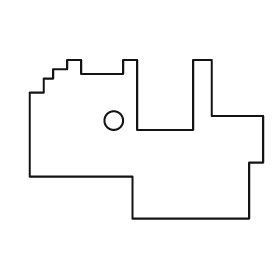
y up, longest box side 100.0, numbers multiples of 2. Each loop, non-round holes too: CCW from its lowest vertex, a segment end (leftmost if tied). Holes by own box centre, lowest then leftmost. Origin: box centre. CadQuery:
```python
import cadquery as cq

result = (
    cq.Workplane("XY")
    .moveTo(-6.0, -34.0)
    .lineTo(44.0, -34.0)
    .lineTo(44.0, -10.0)
    .lineTo(50.0, -10.0)
    .lineTo(50.0, 10.0)
    .lineTo(28.0, 10.0)
    .lineTo(28.0, 34.0)
    .lineTo(20.0, 34.0)
    .lineTo(20.0, 4.0)
    .lineTo(-4.0, 4.0)
    .lineTo(-4.0, 34.0)
    .lineTo(-10.0, 34.0)
    .lineTo(-10.0, 28.0)
    .lineTo(-28.0, 28.0)
    .lineTo(-28.0, 34.0)
    .lineTo(-34.0, 34.0)
    .lineTo(-34.0, 30.0)
    .lineTo(-40.0, 30.0)
    .lineTo(-40.0, 26.0)
    .lineTo(-44.0, 26.0)
    .lineTo(-44.0, 20.0)
    .lineTo(-50.0, 20.0)
    .lineTo(-50.0, -16.0)
    .lineTo(-6.0, -16.0)
    .close()
    .moveTo(-14.0, 8.0)
    .circle(4.0)
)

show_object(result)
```